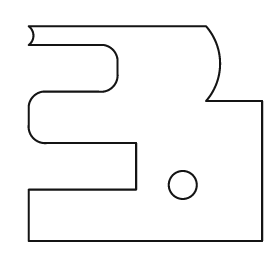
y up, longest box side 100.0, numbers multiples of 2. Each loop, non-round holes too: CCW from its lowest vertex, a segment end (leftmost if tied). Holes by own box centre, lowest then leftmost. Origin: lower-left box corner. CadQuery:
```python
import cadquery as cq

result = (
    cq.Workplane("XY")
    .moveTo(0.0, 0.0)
    .lineTo(100.0, 0.0)
    .lineTo(100.0, 60.0)
    .lineTo(76.0, 60.0)
    .threePointArc((82.0, 76.0), (76.0, 92.0))
    .lineTo(0.0, 92.0)
    .threePointArc((2.0, 88.0), (0.0, 84.0))
    .lineTo(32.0, 84.0)
    .threePointArc((36.0, 82.0), (38.0, 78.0))
    .lineTo(38.0, 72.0)
    .threePointArc((36.0, 66.0), (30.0, 64.0))
    .lineTo(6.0, 64.0)
    .threePointArc((2.0, 62.0), (0.0, 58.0))
    .lineTo(0.0, 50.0)
    .threePointArc((2.0, 44.0), (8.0, 42.0))
    .lineTo(46.0, 42.0)
    .lineTo(46.0, 22.0)
    .lineTo(0.0, 22.0)
    .close()
    .moveTo(66.0, 24.0)
    .circle(6.0)
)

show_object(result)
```